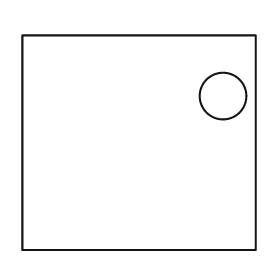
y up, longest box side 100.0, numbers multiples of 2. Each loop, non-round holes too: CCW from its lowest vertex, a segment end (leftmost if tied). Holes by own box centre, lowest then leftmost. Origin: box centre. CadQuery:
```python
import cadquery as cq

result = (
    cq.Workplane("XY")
    .moveTo(-50.0, -46.0)
    .lineTo(50.0, -46.0)
    .lineTo(50.0, 46.0)
    .lineTo(-50.0, 46.0)
    .close()
    .moveTo(36.0, 20.0)
    .circle(10.0)
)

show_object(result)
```